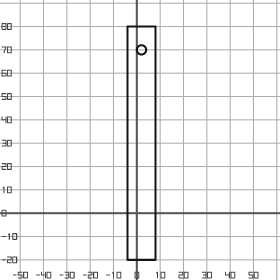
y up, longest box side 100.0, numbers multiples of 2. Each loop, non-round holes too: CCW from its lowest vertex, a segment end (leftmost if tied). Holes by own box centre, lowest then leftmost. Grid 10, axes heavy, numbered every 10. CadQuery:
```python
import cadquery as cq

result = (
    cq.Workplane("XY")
    .moveTo(-4.0, -20.0)
    .lineTo(8.0, -20.0)
    .lineTo(8.0, 80.0)
    .lineTo(-4.0, 80.0)
    .close()
    .moveTo(2.0, 70.0)
    .circle(2.0)
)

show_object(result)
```